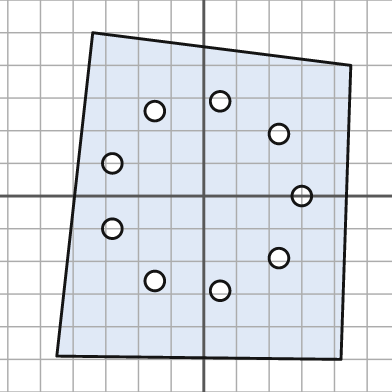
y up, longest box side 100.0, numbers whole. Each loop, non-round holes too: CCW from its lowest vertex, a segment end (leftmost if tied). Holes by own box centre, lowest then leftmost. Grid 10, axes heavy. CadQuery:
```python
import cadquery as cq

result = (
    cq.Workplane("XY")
    .moveTo(42.0, -50.0)
    .lineTo(45.0, 40.0)
    .lineTo(-34.0, 50.0)
    .lineTo(-45.0, -49.0)
    .close()
    .moveTo(5.0, -29.0)
    .circle(3.0)
    .moveTo(-15.0, -26.0)
    .circle(3.0)
    .moveTo(23.0, -19.0)
    .circle(3.0)
    .moveTo(-28.0, -10.0)
    .circle(3.0)
    .moveTo(30.0, 0.0)
    .circle(3.0)
    .moveTo(-28.0, 10.0)
    .circle(3.0)
    .moveTo(23.0, 19.0)
    .circle(3.0)
    .moveTo(-15.0, 26.0)
    .circle(3.0)
    .moveTo(5.0, 29.0)
    .circle(3.0)
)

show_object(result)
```